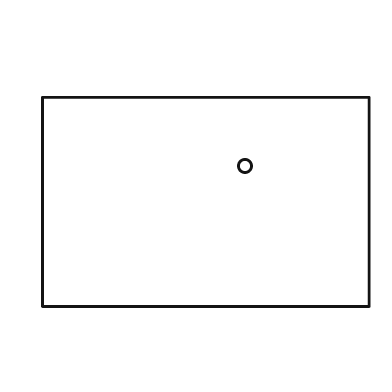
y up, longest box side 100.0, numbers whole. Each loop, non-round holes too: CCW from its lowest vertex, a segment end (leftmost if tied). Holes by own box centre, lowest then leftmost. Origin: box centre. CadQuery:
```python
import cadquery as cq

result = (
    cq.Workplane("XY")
    .moveTo(-50.0, -32.0)
    .lineTo(50.0, -32.0)
    .lineTo(50.0, 32.0)
    .lineTo(-50.0, 32.0)
    .close()
    .moveTo(12.0, 11.0)
    .circle(2.0)
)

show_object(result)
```